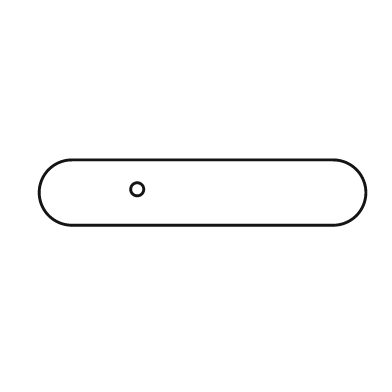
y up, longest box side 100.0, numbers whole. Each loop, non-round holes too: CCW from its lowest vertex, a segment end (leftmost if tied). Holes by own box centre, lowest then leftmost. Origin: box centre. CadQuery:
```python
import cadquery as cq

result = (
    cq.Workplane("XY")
    .moveTo(-40.0, -10.0)
    .lineTo(40.0, -10.0)
    .threePointArc((50.0, 0.0), (40.0, 10.0))
    .lineTo(-40.0, 10.0)
    .threePointArc((-50.0, 0.0), (-40.0, -10.0))
    .close()
    .moveTo(-20.0, 1.0)
    .circle(2.0)
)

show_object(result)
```